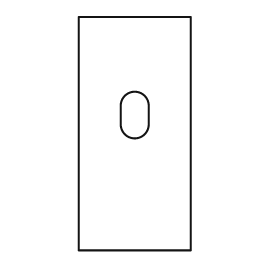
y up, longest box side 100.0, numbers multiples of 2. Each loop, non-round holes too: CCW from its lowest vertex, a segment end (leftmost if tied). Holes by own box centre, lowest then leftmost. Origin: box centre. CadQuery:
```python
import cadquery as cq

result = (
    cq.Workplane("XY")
    .moveTo(-24.0, -50.0)
    .lineTo(24.0, -50.0)
    .lineTo(24.0, 50.0)
    .lineTo(-24.0, 50.0)
    .close()
    .moveTo(-6.0, 4.0)
    .threePointArc((0.0, -2.0), (6.0, 4.0))
    .lineTo(6.0, 12.0)
    .threePointArc((0.0, 18.0), (-6.0, 12.0))
    .close()
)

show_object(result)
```